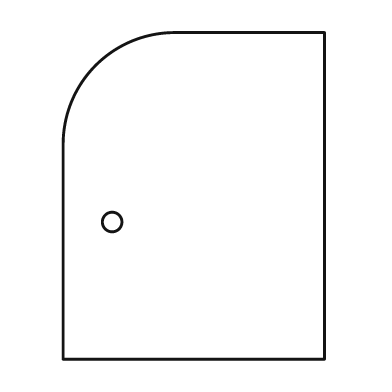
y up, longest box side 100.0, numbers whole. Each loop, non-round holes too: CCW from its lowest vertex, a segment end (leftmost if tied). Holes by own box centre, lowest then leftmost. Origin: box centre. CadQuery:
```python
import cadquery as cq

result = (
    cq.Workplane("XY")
    .moveTo(-40.0, -50.0)
    .lineTo(40.0, -50.0)
    .lineTo(40.0, 50.0)
    .lineTo(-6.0, 50.0)
    .threePointArc((-30.0, 40.0), (-40.0, 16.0))
    .close()
    .moveTo(-25.0, -8.0)
    .circle(3.0)
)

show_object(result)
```